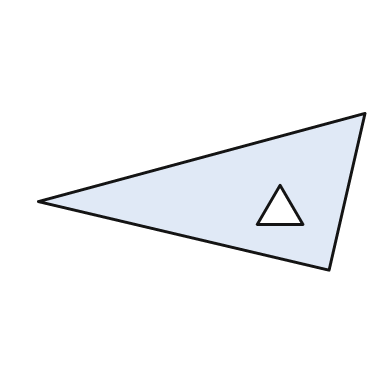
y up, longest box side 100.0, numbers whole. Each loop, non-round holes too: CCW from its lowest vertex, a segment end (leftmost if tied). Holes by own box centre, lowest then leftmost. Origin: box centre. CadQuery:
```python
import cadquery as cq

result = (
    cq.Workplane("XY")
    .moveTo(39.0, -24.0)
    .lineTo(50.0, 24.0)
    .lineTo(-50.0, -3.0)
    .close()
    .moveTo(17.0, -10.0)
    .lineTo(31.0, -10.0)
    .lineTo(24.0, 2.0)
    .close()
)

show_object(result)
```